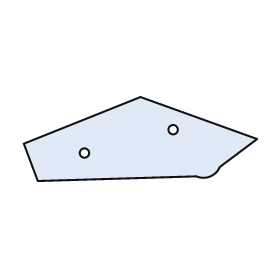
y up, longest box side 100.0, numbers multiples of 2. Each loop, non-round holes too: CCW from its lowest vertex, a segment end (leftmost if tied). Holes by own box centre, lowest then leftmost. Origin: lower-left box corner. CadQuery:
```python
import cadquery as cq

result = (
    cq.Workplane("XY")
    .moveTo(6.0, 0.0)
    .lineTo(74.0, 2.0)
    .threePointArc((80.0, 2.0), (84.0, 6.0))
    .lineTo(100.0, 18.0)
    .lineTo(50.0, 36.0)
    .lineTo(0.0, 16.0)
    .close()
    .moveTo(26.0, 12.0)
    .circle(2.0)
    .moveTo(64.0, 22.0)
    .circle(2.0)
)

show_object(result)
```